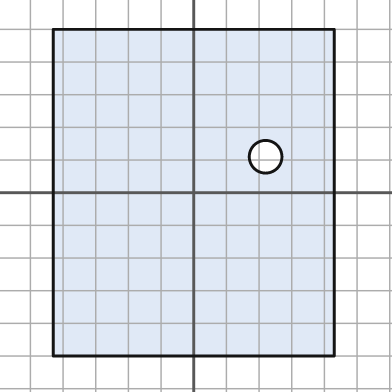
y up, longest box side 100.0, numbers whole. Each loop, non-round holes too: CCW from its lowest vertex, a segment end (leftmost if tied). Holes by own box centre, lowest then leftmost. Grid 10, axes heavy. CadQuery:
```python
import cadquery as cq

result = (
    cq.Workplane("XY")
    .moveTo(-43.0, -50.0)
    .lineTo(43.0, -50.0)
    .lineTo(43.0, 50.0)
    .lineTo(-43.0, 50.0)
    .close()
    .moveTo(22.0, 11.0)
    .circle(5.0)
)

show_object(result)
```